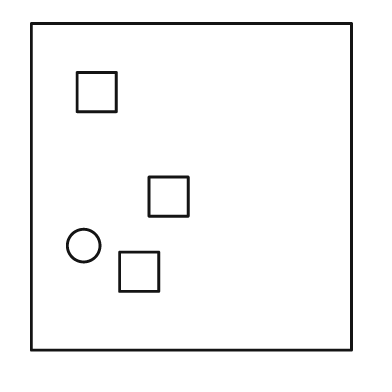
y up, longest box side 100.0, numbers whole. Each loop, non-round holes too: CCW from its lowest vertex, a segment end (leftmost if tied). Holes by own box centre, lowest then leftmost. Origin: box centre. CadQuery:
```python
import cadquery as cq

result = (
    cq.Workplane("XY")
    .moveTo(-49.0, -50.0)
    .lineTo(49.0, -50.0)
    .lineTo(49.0, 50.0)
    .lineTo(-49.0, 50.0)
    .close()
    .moveTo(-22.0, -32.0)
    .lineTo(-10.0, -32.0)
    .lineTo(-10.0, -20.0)
    .lineTo(-22.0, -20.0)
    .close()
    .moveTo(-33.0, -18.0)
    .circle(5.0)
    .moveTo(-13.0, -9.0)
    .lineTo(-1.0, -9.0)
    .lineTo(-1.0, 3.0)
    .lineTo(-13.0, 3.0)
    .close()
    .moveTo(-35.0, 23.0)
    .lineTo(-23.0, 23.0)
    .lineTo(-23.0, 35.0)
    .lineTo(-35.0, 35.0)
    .close()
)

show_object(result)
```